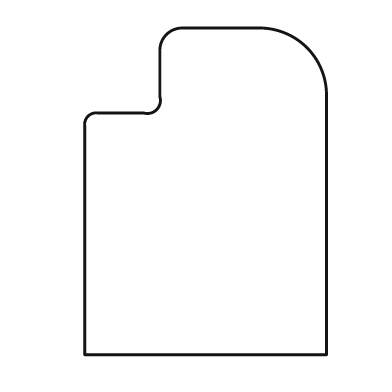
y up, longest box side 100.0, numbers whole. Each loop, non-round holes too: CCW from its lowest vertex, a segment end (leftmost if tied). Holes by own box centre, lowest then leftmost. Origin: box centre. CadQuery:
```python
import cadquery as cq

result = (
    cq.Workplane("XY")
    .moveTo(-37.0, -50.0)
    .lineTo(37.0, -50.0)
    .lineTo(37.0, 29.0)
    .threePointArc((31.0, 44.0), (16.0, 50.0))
    .lineTo(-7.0, 50.0)
    .threePointArc((-12.0, 48.0), (-14.0, 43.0))
    .lineTo(-14.0, 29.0)
    .threePointArc((-15.0, 25.0), (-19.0, 24.0))
    .lineTo(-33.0, 24.0)
    .threePointArc((-36.0, 23.0), (-37.0, 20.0))
    .close()
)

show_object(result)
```